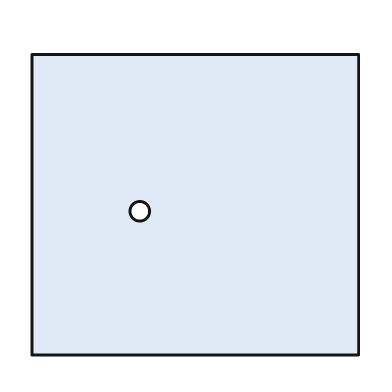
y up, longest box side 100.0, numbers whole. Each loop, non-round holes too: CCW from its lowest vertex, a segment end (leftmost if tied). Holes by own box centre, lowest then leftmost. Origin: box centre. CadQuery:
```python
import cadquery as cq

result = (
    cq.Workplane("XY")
    .moveTo(-50.0, -46.0)
    .lineTo(50.0, -46.0)
    .lineTo(50.0, 46.0)
    .lineTo(-50.0, 46.0)
    .close()
    .moveTo(-17.0, -2.0)
    .circle(3.0)
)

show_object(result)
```